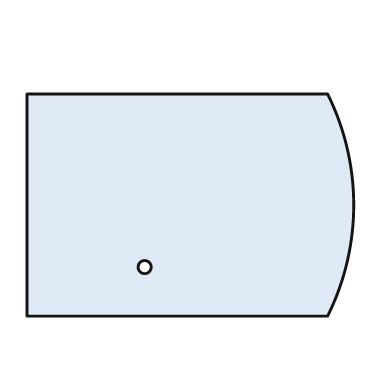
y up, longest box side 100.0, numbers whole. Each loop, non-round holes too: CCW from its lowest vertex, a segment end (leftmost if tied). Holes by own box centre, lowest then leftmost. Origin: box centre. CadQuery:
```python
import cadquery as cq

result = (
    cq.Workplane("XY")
    .moveTo(-50.0, -34.0)
    .lineTo(42.0, -34.0)
    .threePointArc((50.0, 0.0), (42.0, 34.0))
    .lineTo(-50.0, 34.0)
    .close()
    .moveTo(-14.0, -19.0)
    .circle(2.0)
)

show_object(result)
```